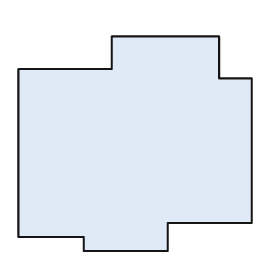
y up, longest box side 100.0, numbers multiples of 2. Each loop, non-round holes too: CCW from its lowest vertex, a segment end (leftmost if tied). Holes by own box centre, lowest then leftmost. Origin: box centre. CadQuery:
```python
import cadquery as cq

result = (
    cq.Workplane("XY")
    .moveTo(-22.0, -46.0)
    .lineTo(14.0, -46.0)
    .lineTo(14.0, -34.0)
    .lineTo(50.0, -34.0)
    .lineTo(50.0, 28.0)
    .lineTo(36.0, 28.0)
    .lineTo(36.0, 46.0)
    .lineTo(-10.0, 46.0)
    .lineTo(-10.0, 32.0)
    .lineTo(-50.0, 32.0)
    .lineTo(-50.0, -40.0)
    .lineTo(-22.0, -40.0)
    .close()
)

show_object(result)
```